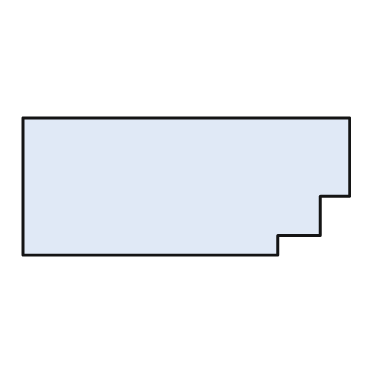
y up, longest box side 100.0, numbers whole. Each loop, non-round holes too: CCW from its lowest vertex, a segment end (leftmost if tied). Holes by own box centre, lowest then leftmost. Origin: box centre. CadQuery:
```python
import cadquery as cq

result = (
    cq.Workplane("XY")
    .moveTo(-50.0, -21.0)
    .lineTo(28.0, -21.0)
    .lineTo(28.0, -15.0)
    .lineTo(41.0, -15.0)
    .lineTo(41.0, -3.0)
    .lineTo(50.0, -3.0)
    .lineTo(50.0, 21.0)
    .lineTo(-50.0, 21.0)
    .close()
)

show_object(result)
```